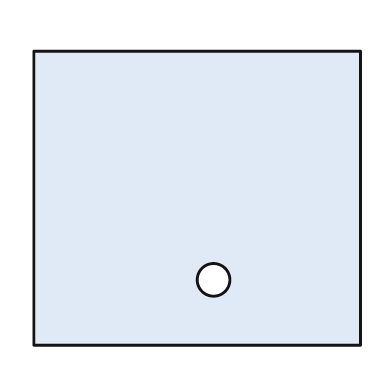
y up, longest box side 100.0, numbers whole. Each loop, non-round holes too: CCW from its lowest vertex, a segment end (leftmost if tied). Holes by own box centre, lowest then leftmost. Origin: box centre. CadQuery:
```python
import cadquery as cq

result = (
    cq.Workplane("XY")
    .moveTo(-50.0, -45.0)
    .lineTo(50.0, -45.0)
    .lineTo(50.0, 45.0)
    .lineTo(-50.0, 45.0)
    .close()
    .moveTo(5.0, -25.0)
    .circle(5.0)
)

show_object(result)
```